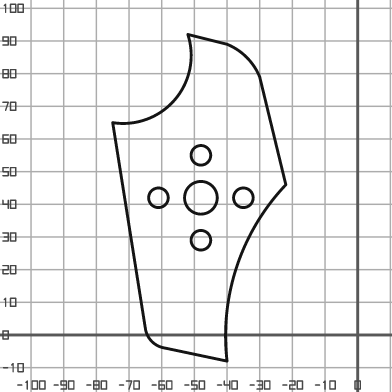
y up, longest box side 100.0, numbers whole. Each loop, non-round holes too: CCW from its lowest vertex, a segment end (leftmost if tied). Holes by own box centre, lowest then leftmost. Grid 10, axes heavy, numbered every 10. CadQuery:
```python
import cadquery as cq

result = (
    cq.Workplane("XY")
    .moveTo(-40.0, -8.0)
    .threePointArc((-37.0, 21.0), (-22.0, 46.0))
    .lineTo(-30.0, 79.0)
    .threePointArc((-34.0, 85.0), (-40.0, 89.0))
    .lineTo(-52.0, 92.0)
    .threePointArc((-56.0, 72.0), (-75.0, 65.0))
    .lineTo(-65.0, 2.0)
    .threePointArc((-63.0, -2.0), (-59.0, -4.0))
    .close()
    .moveTo(-48.0, 29.0)
    .circle(3.0)
    .moveTo(-61.0, 42.0)
    .circle(3.0)
    .moveTo(-48.0, 42.0)
    .circle(5.0)
    .moveTo(-35.0, 42.0)
    .circle(3.0)
    .moveTo(-48.0, 55.0)
    .circle(3.0)
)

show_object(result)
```